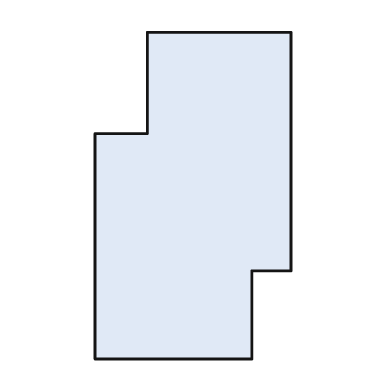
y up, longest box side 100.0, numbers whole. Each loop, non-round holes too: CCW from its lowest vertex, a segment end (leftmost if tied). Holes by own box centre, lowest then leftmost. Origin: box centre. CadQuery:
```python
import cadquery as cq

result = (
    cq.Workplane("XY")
    .moveTo(-30.0, -50.0)
    .lineTo(18.0, -50.0)
    .lineTo(18.0, -23.0)
    .lineTo(30.0, -23.0)
    .lineTo(30.0, 50.0)
    .lineTo(-14.0, 50.0)
    .lineTo(-14.0, 19.0)
    .lineTo(-30.0, 19.0)
    .close()
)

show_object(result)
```